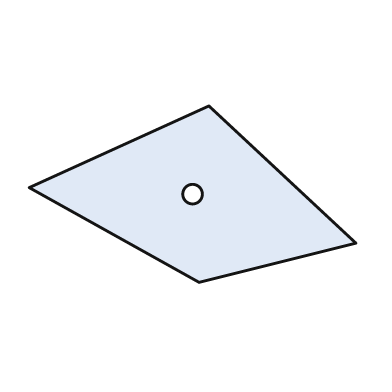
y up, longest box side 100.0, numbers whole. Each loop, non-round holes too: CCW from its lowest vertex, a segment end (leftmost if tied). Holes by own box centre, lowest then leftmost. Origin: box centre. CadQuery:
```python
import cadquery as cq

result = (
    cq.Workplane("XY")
    .moveTo(2.0, -27.0)
    .lineTo(50.0, -15.0)
    .lineTo(5.0, 27.0)
    .lineTo(-50.0, 2.0)
    .close()
    .moveTo(0.0, 0.0)
    .circle(3.0)
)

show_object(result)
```